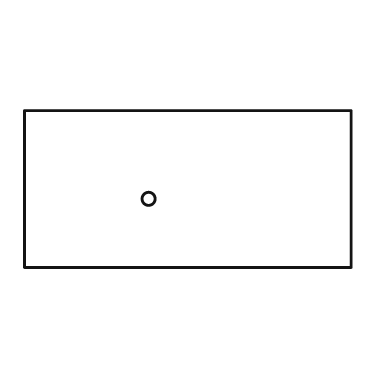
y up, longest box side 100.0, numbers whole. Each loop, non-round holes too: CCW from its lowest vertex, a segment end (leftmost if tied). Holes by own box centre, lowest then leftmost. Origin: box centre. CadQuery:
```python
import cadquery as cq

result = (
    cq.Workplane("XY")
    .moveTo(-50.0, -24.0)
    .lineTo(50.0, -24.0)
    .lineTo(50.0, 24.0)
    .lineTo(-50.0, 24.0)
    .close()
    .moveTo(-12.0, -3.0)
    .circle(2.0)
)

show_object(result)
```